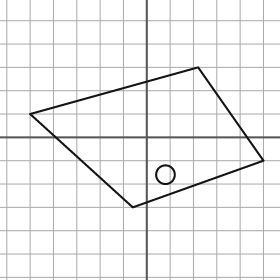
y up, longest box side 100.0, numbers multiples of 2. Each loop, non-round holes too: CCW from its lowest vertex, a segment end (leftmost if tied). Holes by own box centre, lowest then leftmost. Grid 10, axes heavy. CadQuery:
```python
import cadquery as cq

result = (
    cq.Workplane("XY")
    .moveTo(-6.0, -30.0)
    .lineTo(50.0, -10.0)
    .lineTo(22.0, 30.0)
    .lineTo(-50.0, 10.0)
    .close()
    .moveTo(8.0, -16.0)
    .circle(4.0)
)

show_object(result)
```